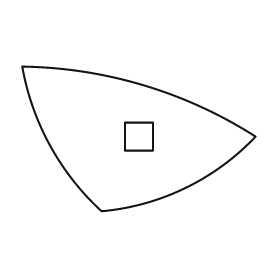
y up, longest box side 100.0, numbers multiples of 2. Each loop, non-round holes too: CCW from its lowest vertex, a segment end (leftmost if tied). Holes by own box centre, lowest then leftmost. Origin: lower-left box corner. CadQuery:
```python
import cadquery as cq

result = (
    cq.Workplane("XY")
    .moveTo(34.0, 0.0)
    .threePointArc((70.0, 10.0), (100.0, 32.0))
    .threePointArc((52.0, 54.0), (0.0, 62.0))
    .threePointArc((12.0, 28.0), (34.0, 0.0))
    .close()
    .moveTo(44.0, 26.0)
    .lineTo(56.0, 26.0)
    .lineTo(56.0, 38.0)
    .lineTo(44.0, 38.0)
    .close()
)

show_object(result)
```